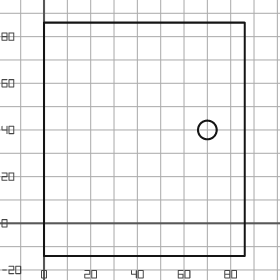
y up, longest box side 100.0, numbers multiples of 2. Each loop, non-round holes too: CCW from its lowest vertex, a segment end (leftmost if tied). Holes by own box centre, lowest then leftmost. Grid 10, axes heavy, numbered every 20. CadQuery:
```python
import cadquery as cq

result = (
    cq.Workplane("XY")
    .moveTo(0.0, -14.0)
    .lineTo(86.0, -14.0)
    .lineTo(86.0, 86.0)
    .lineTo(0.0, 86.0)
    .close()
    .moveTo(70.0, 40.0)
    .circle(4.0)
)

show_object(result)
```